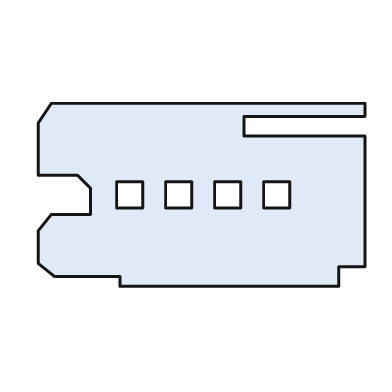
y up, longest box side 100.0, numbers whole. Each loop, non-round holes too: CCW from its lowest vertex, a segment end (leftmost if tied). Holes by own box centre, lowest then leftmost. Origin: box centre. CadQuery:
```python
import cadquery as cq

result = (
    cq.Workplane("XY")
    .moveTo(-25.0, -28.0)
    .lineTo(42.0, -28.0)
    .lineTo(42.0, -22.0)
    .lineTo(50.0, -22.0)
    .lineTo(50.0, 18.0)
    .lineTo(13.0, 18.0)
    .lineTo(13.0, 24.0)
    .lineTo(50.0, 24.0)
    .lineTo(50.0, 28.0)
    .lineTo(-46.0, 28.0)
    .lineTo(-50.0, 22.0)
    .lineTo(-50.0, 6.0)
    .lineTo(-38.0, 6.0)
    .lineTo(-34.0, 2.0)
    .lineTo(-34.0, -6.0)
    .lineTo(-46.0, -6.0)
    .lineTo(-50.0, -11.0)
    .lineTo(-50.0, -21.0)
    .lineTo(-45.0, -25.0)
    .lineTo(-25.0, -25.0)
    .close()
    .moveTo(-26.0, -4.0)
    .lineTo(-18.0, -4.0)
    .lineTo(-18.0, 4.0)
    .lineTo(-26.0, 4.0)
    .close()
    .moveTo(-11.0, -4.0)
    .lineTo(-3.0, -4.0)
    .lineTo(-3.0, 4.0)
    .lineTo(-11.0, 4.0)
    .close()
    .moveTo(4.0, -4.0)
    .lineTo(12.0, -4.0)
    .lineTo(12.0, 4.0)
    .lineTo(4.0, 4.0)
    .close()
    .moveTo(19.0, -4.0)
    .lineTo(27.0, -4.0)
    .lineTo(27.0, 4.0)
    .lineTo(19.0, 4.0)
    .close()
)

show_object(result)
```